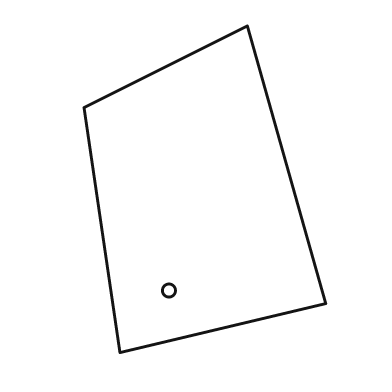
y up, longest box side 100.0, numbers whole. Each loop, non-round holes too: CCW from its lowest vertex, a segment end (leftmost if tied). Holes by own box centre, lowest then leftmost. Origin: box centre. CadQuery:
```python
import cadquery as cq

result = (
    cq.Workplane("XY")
    .moveTo(-26.0, -50.0)
    .lineTo(37.0, -35.0)
    .lineTo(13.0, 50.0)
    .lineTo(-37.0, 25.0)
    .close()
    .moveTo(-11.0, -31.0)
    .circle(2.0)
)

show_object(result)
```